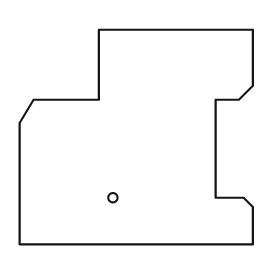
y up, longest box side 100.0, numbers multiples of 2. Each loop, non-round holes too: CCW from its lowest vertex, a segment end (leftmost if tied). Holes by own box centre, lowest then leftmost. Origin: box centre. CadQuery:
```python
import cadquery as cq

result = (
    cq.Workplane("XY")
    .moveTo(-50.0, -46.0)
    .lineTo(50.0, -46.0)
    .lineTo(50.0, -30.0)
    .lineTo(46.0, -26.0)
    .lineTo(34.0, -26.0)
    .lineTo(34.0, 16.0)
    .lineTo(44.0, 16.0)
    .lineTo(50.0, 22.0)
    .lineTo(50.0, 46.0)
    .lineTo(-16.0, 46.0)
    .lineTo(-16.0, 16.0)
    .lineTo(-44.0, 16.0)
    .lineTo(-50.0, 6.0)
    .close()
    .moveTo(-10.0, -26.0)
    .circle(2.0)
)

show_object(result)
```